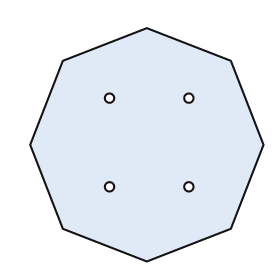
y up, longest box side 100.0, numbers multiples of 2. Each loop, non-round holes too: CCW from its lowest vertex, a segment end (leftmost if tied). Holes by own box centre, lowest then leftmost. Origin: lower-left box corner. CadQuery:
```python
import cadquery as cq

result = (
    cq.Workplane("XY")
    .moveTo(50.0, 0.0)
    .lineTo(86.0, 14.0)
    .lineTo(100.0, 50.0)
    .lineTo(86.0, 86.0)
    .lineTo(50.0, 100.0)
    .lineTo(14.0, 86.0)
    .lineTo(0.0, 50.0)
    .lineTo(14.0, 14.0)
    .close()
    .moveTo(34.0, 32.0)
    .circle(2.0)
    .moveTo(68.0, 32.0)
    .circle(2.0)
    .moveTo(34.0, 70.0)
    .circle(2.0)
    .moveTo(68.0, 70.0)
    .circle(2.0)
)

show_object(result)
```